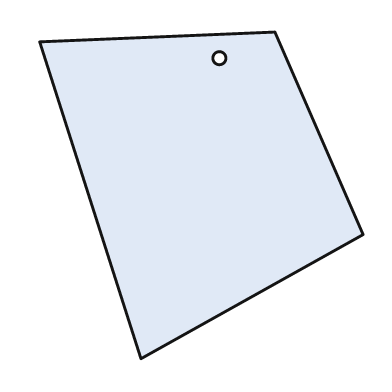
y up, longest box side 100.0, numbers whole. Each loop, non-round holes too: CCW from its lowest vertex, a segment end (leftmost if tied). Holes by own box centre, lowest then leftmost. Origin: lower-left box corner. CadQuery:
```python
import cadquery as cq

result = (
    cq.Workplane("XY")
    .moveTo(31.0, 0.0)
    .lineTo(99.0, 38.0)
    .lineTo(72.0, 100.0)
    .lineTo(0.0, 97.0)
    .close()
    .moveTo(55.0, 92.0)
    .circle(2.0)
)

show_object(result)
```